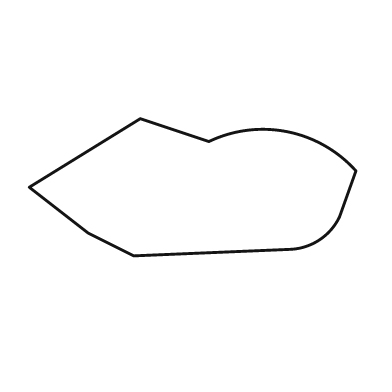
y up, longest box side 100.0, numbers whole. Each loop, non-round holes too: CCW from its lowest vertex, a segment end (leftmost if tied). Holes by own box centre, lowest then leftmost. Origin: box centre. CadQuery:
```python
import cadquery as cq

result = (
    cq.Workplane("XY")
    .moveTo(-18.0, -21.0)
    .lineTo(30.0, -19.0)
    .threePointArc((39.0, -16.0), (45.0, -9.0))
    .lineTo(50.0, 5.0)
    .threePointArc((29.0, 17.0), (5.0, 14.0))
    .lineTo(-16.0, 21.0)
    .lineTo(-50.0, 0.0)
    .lineTo(-32.0, -14.0)
    .close()
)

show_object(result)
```